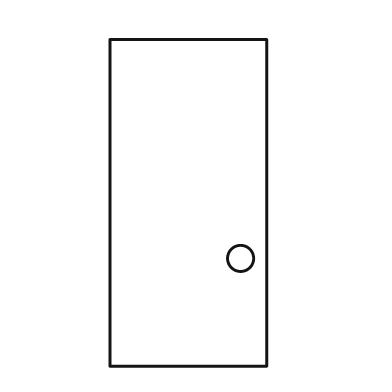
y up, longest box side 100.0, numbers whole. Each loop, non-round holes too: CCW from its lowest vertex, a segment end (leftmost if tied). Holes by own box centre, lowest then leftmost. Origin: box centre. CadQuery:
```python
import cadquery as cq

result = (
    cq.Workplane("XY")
    .moveTo(-24.0, -50.0)
    .lineTo(24.0, -50.0)
    .lineTo(24.0, 50.0)
    .lineTo(-24.0, 50.0)
    .close()
    .moveTo(16.0, -17.0)
    .circle(4.0)
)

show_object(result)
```